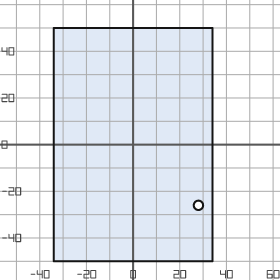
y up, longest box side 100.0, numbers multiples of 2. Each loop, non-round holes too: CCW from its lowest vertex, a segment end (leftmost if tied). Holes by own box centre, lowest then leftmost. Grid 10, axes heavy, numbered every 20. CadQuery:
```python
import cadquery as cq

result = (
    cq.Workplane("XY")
    .moveTo(-34.0, -50.0)
    .lineTo(34.0, -50.0)
    .lineTo(34.0, 50.0)
    .lineTo(-34.0, 50.0)
    .close()
    .moveTo(28.0, -26.0)
    .circle(2.0)
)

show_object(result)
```